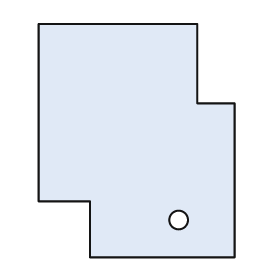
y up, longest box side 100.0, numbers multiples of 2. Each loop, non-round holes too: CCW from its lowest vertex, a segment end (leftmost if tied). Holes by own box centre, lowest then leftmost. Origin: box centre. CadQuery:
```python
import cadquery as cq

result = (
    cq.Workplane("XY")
    .moveTo(-20.0, -50.0)
    .lineTo(42.0, -50.0)
    .lineTo(42.0, 16.0)
    .lineTo(26.0, 16.0)
    .lineTo(26.0, 50.0)
    .lineTo(-42.0, 50.0)
    .lineTo(-42.0, -26.0)
    .lineTo(-20.0, -26.0)
    .close()
    .moveTo(18.0, -34.0)
    .circle(4.0)
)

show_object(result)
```